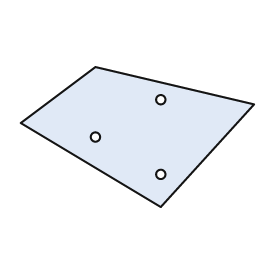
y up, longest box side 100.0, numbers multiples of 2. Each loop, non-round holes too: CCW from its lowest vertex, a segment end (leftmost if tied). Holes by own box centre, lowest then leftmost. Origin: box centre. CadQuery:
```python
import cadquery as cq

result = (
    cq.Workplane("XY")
    .moveTo(10.0, -30.0)
    .lineTo(50.0, 14.0)
    .lineTo(-18.0, 30.0)
    .lineTo(-50.0, 6.0)
    .close()
    .moveTo(10.0, -16.0)
    .circle(2.0)
    .moveTo(-18.0, 0.0)
    .circle(2.0)
    .moveTo(10.0, 16.0)
    .circle(2.0)
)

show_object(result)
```